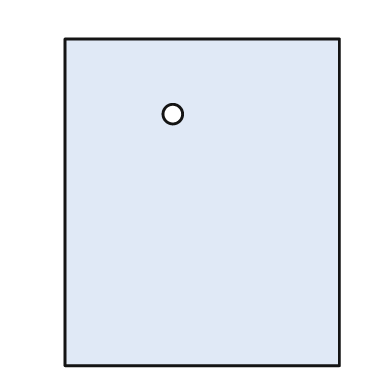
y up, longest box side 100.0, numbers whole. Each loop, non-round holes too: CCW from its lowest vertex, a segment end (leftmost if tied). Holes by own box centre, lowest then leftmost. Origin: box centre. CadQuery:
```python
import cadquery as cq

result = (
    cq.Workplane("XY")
    .moveTo(-42.0, -50.0)
    .lineTo(42.0, -50.0)
    .lineTo(42.0, 50.0)
    .lineTo(-42.0, 50.0)
    .close()
    .moveTo(-9.0, 27.0)
    .circle(3.0)
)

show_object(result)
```